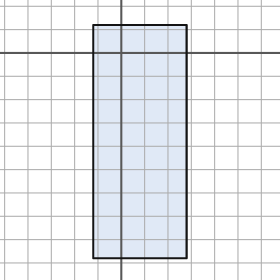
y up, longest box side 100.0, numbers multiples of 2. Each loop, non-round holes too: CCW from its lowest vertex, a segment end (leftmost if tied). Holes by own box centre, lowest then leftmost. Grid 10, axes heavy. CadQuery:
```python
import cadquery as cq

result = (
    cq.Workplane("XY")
    .moveTo(-12.0, -88.0)
    .lineTo(28.0, -88.0)
    .lineTo(28.0, 12.0)
    .lineTo(-12.0, 12.0)
    .close()
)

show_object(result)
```